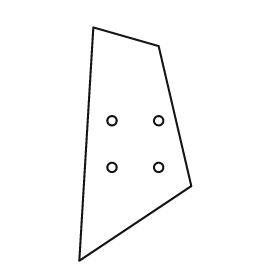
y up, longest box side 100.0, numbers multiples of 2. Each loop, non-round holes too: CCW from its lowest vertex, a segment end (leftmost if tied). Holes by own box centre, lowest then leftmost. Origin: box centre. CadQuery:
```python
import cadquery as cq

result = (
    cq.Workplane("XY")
    .moveTo(-24.0, -50.0)
    .lineTo(24.0, -18.0)
    .lineTo(10.0, 42.0)
    .lineTo(-18.0, 50.0)
    .close()
    .moveTo(-10.0, -10.0)
    .circle(2.0)
    .moveTo(10.0, -10.0)
    .circle(2.0)
    .moveTo(-10.0, 10.0)
    .circle(2.0)
    .moveTo(10.0, 10.0)
    .circle(2.0)
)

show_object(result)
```